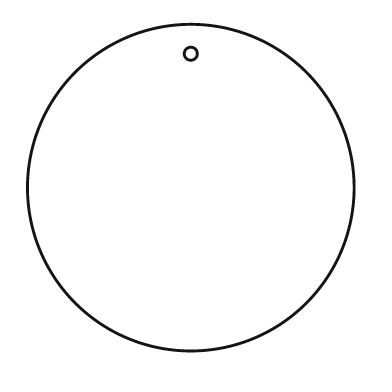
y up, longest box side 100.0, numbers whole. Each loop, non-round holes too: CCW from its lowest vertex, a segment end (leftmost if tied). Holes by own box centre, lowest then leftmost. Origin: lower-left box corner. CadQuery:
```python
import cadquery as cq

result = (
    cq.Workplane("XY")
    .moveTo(50.0, 50.0)
    .circle(50.0)
    .moveTo(50.0, 91.0)
    .circle(2.0)
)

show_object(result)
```